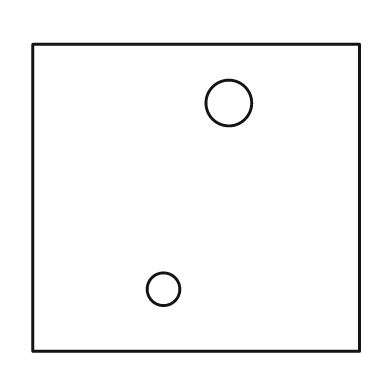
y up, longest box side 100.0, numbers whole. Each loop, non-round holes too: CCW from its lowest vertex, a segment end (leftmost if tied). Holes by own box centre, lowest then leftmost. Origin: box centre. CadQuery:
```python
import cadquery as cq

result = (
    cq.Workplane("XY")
    .moveTo(-50.0, -47.0)
    .lineTo(50.0, -47.0)
    .lineTo(50.0, 47.0)
    .lineTo(-50.0, 47.0)
    .close()
    .moveTo(-10.0, -28.0)
    .circle(5.0)
    .moveTo(10.0, 29.0)
    .circle(7.0)
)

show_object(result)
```